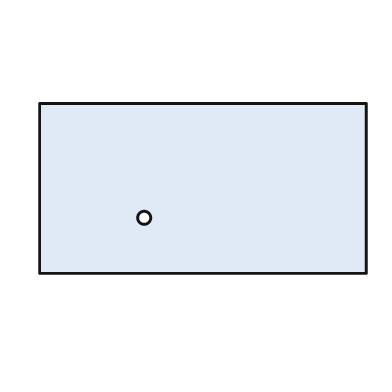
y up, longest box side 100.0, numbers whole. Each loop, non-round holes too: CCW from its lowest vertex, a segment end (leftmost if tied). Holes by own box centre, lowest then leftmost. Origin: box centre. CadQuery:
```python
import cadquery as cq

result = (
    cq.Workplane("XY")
    .moveTo(-50.0, -26.0)
    .lineTo(50.0, -26.0)
    .lineTo(50.0, 26.0)
    .lineTo(-50.0, 26.0)
    .close()
    .moveTo(-18.0, -9.0)
    .circle(2.0)
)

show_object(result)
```